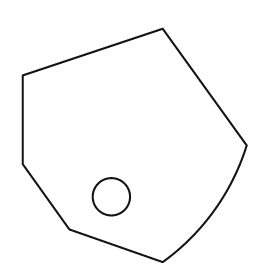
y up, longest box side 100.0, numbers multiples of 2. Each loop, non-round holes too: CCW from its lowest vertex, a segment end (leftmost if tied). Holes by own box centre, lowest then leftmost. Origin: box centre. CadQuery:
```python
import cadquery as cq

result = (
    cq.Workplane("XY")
    .moveTo(12.0, -50.0)
    .threePointArc((34.0, -28.0), (48.0, 0.0))
    .lineTo(12.0, 50.0)
    .lineTo(-48.0, 30.0)
    .lineTo(-48.0, -8.0)
    .lineTo(-28.0, -36.0)
    .close()
    .moveTo(-10.0, -22.0)
    .circle(8.0)
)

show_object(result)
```